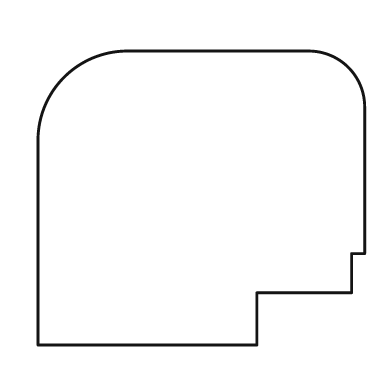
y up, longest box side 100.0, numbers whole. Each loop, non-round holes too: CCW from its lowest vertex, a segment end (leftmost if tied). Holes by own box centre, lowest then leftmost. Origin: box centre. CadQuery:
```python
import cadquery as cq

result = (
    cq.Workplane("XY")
    .moveTo(-50.0, -45.0)
    .lineTo(17.0, -45.0)
    .lineTo(17.0, -29.0)
    .lineTo(46.0, -29.0)
    .lineTo(46.0, -17.0)
    .lineTo(50.0, -17.0)
    .lineTo(50.0, 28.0)
    .threePointArc((45.0, 40.0), (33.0, 45.0))
    .lineTo(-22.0, 45.0)
    .threePointArc((-42.0, 37.0), (-50.0, 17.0))
    .close()
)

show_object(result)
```